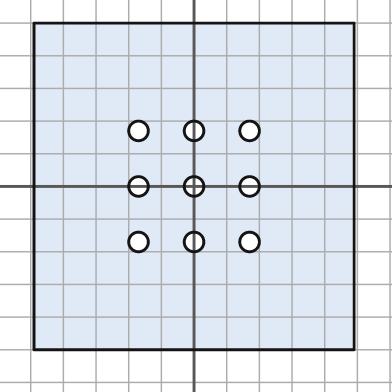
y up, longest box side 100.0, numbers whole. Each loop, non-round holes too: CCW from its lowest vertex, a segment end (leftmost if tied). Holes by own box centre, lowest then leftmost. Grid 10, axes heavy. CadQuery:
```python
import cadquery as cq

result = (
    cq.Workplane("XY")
    .moveTo(-49.0, -50.0)
    .lineTo(49.0, -50.0)
    .lineTo(49.0, 50.0)
    .lineTo(-49.0, 50.0)
    .close()
    .moveTo(-17.0, -17.0)
    .circle(3.0)
    .moveTo(0.0, -17.0)
    .circle(3.0)
    .moveTo(17.0, -17.0)
    .circle(3.0)
    .moveTo(-17.0, 0.0)
    .circle(3.0)
    .moveTo(0.0, 0.0)
    .circle(3.0)
    .moveTo(17.0, 0.0)
    .circle(3.0)
    .moveTo(-17.0, 17.0)
    .circle(3.0)
    .moveTo(0.0, 17.0)
    .circle(3.0)
    .moveTo(17.0, 17.0)
    .circle(3.0)
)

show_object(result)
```